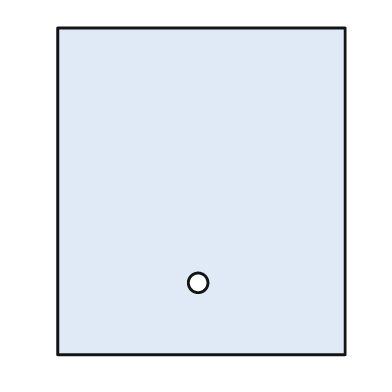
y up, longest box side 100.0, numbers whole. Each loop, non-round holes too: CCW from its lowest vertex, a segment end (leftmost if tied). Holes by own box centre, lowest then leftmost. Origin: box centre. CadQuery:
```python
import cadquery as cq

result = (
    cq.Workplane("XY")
    .moveTo(-44.0, -50.0)
    .lineTo(44.0, -50.0)
    .lineTo(44.0, 50.0)
    .lineTo(-44.0, 50.0)
    .close()
    .moveTo(-1.0, -28.0)
    .circle(3.0)
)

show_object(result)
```